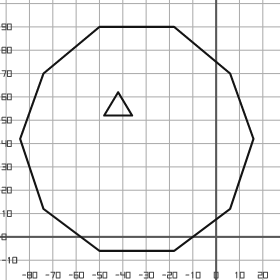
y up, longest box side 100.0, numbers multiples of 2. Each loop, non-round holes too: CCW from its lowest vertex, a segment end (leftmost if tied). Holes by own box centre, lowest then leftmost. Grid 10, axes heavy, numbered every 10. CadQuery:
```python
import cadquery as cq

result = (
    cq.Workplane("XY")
    .moveTo(-50.0, -6.0)
    .lineTo(-18.0, -6.0)
    .lineTo(6.0, 12.0)
    .lineTo(16.0, 42.0)
    .lineTo(6.0, 70.0)
    .lineTo(-18.0, 90.0)
    .lineTo(-50.0, 90.0)
    .lineTo(-74.0, 70.0)
    .lineTo(-84.0, 42.0)
    .lineTo(-74.0, 12.0)
    .close()
    .moveTo(-48.0, 52.0)
    .lineTo(-36.0, 52.0)
    .lineTo(-42.0, 62.0)
    .close()
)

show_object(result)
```